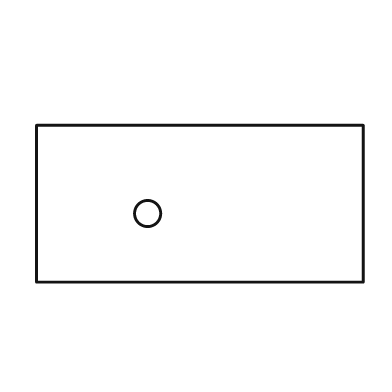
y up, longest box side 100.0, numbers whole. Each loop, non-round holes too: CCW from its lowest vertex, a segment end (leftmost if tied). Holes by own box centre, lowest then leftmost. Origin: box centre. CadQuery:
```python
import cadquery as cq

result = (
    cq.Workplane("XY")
    .moveTo(-50.0, -24.0)
    .lineTo(50.0, -24.0)
    .lineTo(50.0, 24.0)
    .lineTo(-50.0, 24.0)
    .close()
    .moveTo(-16.0, -3.0)
    .circle(4.0)
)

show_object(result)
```